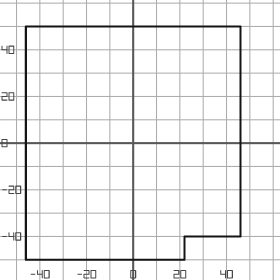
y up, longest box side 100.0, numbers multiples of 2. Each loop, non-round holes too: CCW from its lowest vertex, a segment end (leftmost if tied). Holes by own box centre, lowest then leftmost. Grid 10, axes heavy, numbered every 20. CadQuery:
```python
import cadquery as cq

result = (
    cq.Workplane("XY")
    .moveTo(-46.0, -50.0)
    .lineTo(22.0, -50.0)
    .lineTo(22.0, -40.0)
    .lineTo(46.0, -40.0)
    .lineTo(46.0, 50.0)
    .lineTo(-46.0, 50.0)
    .close()
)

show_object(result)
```